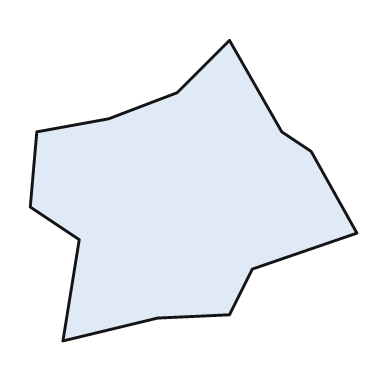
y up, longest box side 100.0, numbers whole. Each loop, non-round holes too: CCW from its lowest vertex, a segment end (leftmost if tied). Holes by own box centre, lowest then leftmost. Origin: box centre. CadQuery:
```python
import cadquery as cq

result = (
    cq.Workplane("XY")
    .moveTo(-40.0, -46.0)
    .lineTo(-11.0, -39.0)
    .lineTo(11.0, -38.0)
    .lineTo(18.0, -24.0)
    .lineTo(50.0, -13.0)
    .lineTo(36.0, 12.0)
    .lineTo(27.0, 18.0)
    .lineTo(11.0, 46.0)
    .lineTo(-5.0, 30.0)
    .lineTo(-26.0, 22.0)
    .lineTo(-48.0, 18.0)
    .lineTo(-50.0, -5.0)
    .lineTo(-35.0, -15.0)
    .close()
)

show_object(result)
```